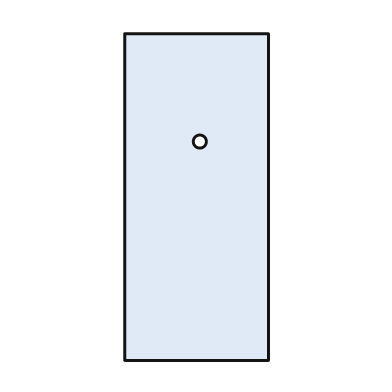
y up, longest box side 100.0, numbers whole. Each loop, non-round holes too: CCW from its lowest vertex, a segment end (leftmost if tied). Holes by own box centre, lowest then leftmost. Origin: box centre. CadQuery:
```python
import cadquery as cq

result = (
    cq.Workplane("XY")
    .moveTo(-22.0, -50.0)
    .lineTo(22.0, -50.0)
    .lineTo(22.0, 50.0)
    .lineTo(-22.0, 50.0)
    .close()
    .moveTo(1.0, 17.0)
    .circle(2.0)
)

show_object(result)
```